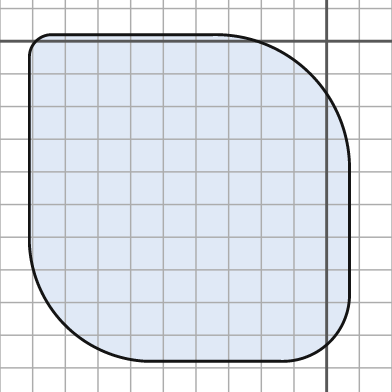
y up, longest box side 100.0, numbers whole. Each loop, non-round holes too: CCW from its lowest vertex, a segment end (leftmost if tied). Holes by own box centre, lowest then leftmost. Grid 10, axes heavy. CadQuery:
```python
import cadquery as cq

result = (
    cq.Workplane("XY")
    .moveTo(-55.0, -98.0)
    .lineTo(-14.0, -98.0)
    .threePointArc((1.0, -92.0), (7.0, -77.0))
    .lineTo(7.0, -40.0)
    .threePointArc((-5.0, -10.0), (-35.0, 2.0))
    .lineTo(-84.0, 2.0)
    .threePointArc((-89.0, 0.0), (-91.0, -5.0))
    .lineTo(-91.0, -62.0)
    .threePointArc((-80.0, -87.0), (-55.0, -98.0))
    .close()
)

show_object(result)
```